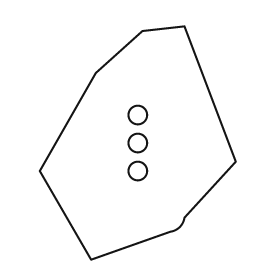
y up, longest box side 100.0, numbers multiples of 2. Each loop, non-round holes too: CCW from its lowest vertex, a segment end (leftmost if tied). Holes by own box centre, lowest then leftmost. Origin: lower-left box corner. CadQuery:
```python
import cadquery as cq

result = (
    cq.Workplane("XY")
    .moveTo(22.0, 0.0)
    .lineTo(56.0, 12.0)
    .threePointArc((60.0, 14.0), (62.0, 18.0))
    .lineTo(84.0, 42.0)
    .lineTo(62.0, 100.0)
    .lineTo(44.0, 98.0)
    .lineTo(24.0, 80.0)
    .lineTo(0.0, 38.0)
    .close()
    .moveTo(42.0, 38.0)
    .circle(4.0)
    .moveTo(42.0, 50.0)
    .circle(4.0)
    .moveTo(42.0, 62.0)
    .circle(4.0)
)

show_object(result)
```